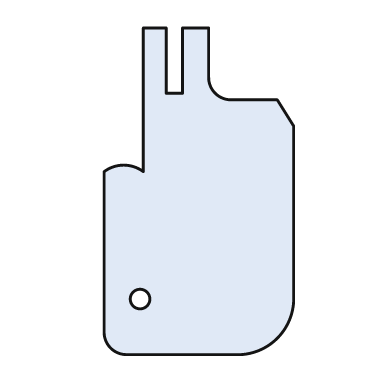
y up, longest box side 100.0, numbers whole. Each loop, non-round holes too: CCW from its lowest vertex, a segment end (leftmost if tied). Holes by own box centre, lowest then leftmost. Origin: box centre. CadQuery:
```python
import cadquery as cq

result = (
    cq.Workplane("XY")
    .moveTo(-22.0, -50.0)
    .lineTo(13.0, -50.0)
    .threePointArc((24.0, -45.0), (29.0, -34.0))
    .lineTo(29.0, 20.0)
    .lineTo(24.0, 28.0)
    .lineTo(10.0, 28.0)
    .threePointArc((5.0, 30.0), (3.0, 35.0))
    .lineTo(3.0, 50.0)
    .lineTo(-5.0, 50.0)
    .lineTo(-5.0, 30.0)
    .lineTo(-10.0, 30.0)
    .lineTo(-10.0, 50.0)
    .lineTo(-17.0, 50.0)
    .lineTo(-17.0, 6.0)
    .threePointArc((-23.0, 8.0), (-29.0, 6.0))
    .lineTo(-29.0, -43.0)
    .threePointArc((-27.0, -48.0), (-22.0, -50.0))
    .close()
    .moveTo(-18.0, -33.0)
    .circle(3.0)
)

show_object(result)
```